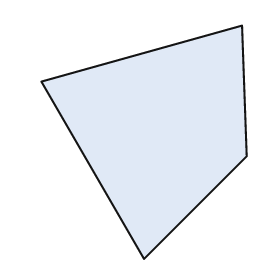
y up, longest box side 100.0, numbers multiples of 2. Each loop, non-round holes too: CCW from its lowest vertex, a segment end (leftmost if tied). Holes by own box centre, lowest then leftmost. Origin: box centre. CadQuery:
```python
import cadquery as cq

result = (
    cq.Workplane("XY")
    .moveTo(0.0, -50.0)
    .lineTo(44.0, -6.0)
    .lineTo(42.0, 50.0)
    .lineTo(-44.0, 26.0)
    .close()
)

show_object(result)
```